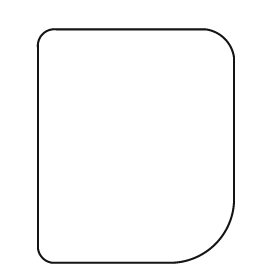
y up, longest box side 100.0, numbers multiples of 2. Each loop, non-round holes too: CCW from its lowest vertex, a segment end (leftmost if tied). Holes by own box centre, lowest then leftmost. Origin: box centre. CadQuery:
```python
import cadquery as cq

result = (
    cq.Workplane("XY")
    .moveTo(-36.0, -50.0)
    .lineTo(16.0, -50.0)
    .threePointArc((34.0, -42.0), (42.0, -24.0))
    .lineTo(42.0, 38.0)
    .threePointArc((38.0, 46.0), (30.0, 50.0))
    .lineTo(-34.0, 50.0)
    .threePointArc((-40.0, 48.0), (-42.0, 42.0))
    .lineTo(-42.0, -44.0)
    .threePointArc((-40.0, -48.0), (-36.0, -50.0))
    .close()
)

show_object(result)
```